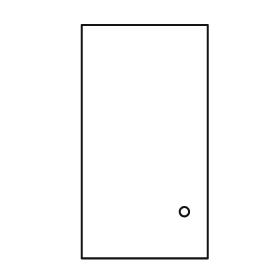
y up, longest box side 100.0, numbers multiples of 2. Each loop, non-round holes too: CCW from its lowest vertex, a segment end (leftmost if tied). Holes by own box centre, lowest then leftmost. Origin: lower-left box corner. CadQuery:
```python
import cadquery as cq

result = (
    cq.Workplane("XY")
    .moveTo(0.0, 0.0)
    .lineTo(54.0, 0.0)
    .lineTo(54.0, 100.0)
    .lineTo(0.0, 100.0)
    .close()
    .moveTo(44.0, 20.0)
    .circle(2.0)
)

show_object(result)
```